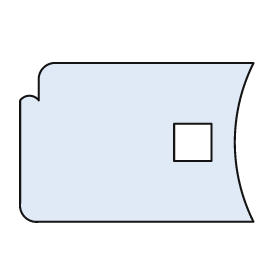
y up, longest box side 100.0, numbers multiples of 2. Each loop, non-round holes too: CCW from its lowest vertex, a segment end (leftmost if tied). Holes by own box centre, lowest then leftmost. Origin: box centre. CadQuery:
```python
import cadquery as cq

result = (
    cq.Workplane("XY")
    .moveTo(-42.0, -34.0)
    .lineTo(50.0, -34.0)
    .threePointArc((42.0, 0.0), (50.0, 34.0))
    .lineTo(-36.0, 34.0)
    .threePointArc((-40.0, 32.0), (-42.0, 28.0))
    .lineTo(-42.0, 18.0)
    .threePointArc((-46.0, 20.0), (-50.0, 18.0))
    .lineTo(-50.0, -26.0)
    .threePointArc((-48.0, -32.0), (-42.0, -34.0))
    .close()
    .moveTo(16.0, -8.0)
    .lineTo(32.0, -8.0)
    .lineTo(32.0, 8.0)
    .lineTo(16.0, 8.0)
    .close()
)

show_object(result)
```